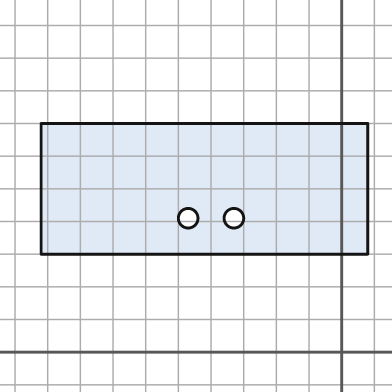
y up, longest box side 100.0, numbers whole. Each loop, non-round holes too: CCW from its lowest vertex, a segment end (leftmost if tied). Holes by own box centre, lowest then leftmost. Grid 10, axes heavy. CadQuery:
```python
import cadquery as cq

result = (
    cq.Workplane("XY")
    .moveTo(-92.0, 30.0)
    .lineTo(8.0, 30.0)
    .lineTo(8.0, 70.0)
    .lineTo(-92.0, 70.0)
    .close()
    .moveTo(-47.0, 41.0)
    .circle(3.0)
    .moveTo(-33.0, 41.0)
    .circle(3.0)
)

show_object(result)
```